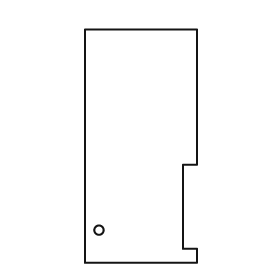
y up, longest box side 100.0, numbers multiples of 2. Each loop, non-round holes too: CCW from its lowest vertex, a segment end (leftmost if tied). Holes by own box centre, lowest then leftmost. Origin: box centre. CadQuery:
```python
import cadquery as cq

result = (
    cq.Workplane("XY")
    .moveTo(-24.0, -50.0)
    .lineTo(24.0, -50.0)
    .lineTo(24.0, -44.0)
    .lineTo(18.0, -44.0)
    .lineTo(18.0, -8.0)
    .lineTo(24.0, -8.0)
    .lineTo(24.0, 50.0)
    .lineTo(-24.0, 50.0)
    .close()
    .moveTo(-18.0, -36.0)
    .circle(2.0)
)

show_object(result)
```